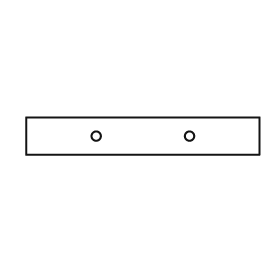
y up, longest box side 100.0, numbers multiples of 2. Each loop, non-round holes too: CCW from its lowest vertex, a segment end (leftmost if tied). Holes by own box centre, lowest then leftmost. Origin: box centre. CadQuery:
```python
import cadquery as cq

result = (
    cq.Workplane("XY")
    .moveTo(-50.0, -8.0)
    .lineTo(50.0, -8.0)
    .lineTo(50.0, 8.0)
    .lineTo(-50.0, 8.0)
    .close()
    .moveTo(-20.0, 0.0)
    .circle(2.0)
    .moveTo(20.0, 0.0)
    .circle(2.0)
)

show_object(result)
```